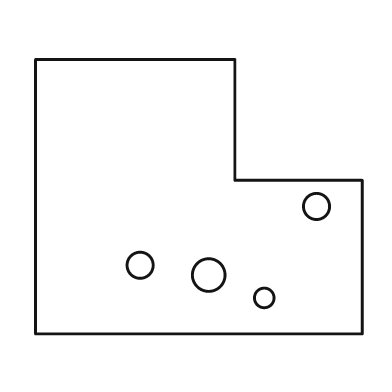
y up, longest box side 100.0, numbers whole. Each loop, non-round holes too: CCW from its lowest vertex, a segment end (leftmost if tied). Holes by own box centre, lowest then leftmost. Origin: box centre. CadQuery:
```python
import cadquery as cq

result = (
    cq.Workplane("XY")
    .moveTo(-50.0, -42.0)
    .lineTo(50.0, -42.0)
    .lineTo(50.0, 5.0)
    .lineTo(11.0, 5.0)
    .lineTo(11.0, 42.0)
    .lineTo(-50.0, 42.0)
    .close()
    .moveTo(20.0, -31.0)
    .circle(3.0)
    .moveTo(3.0, -24.0)
    .circle(5.0)
    .moveTo(-18.0, -21.0)
    .circle(4.0)
    .moveTo(36.0, -3.0)
    .circle(4.0)
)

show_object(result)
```